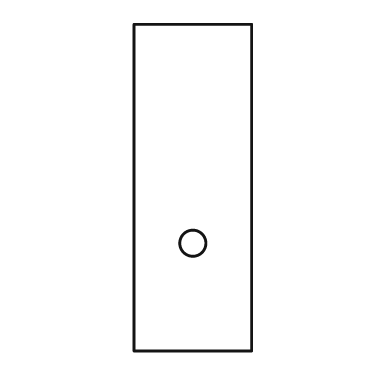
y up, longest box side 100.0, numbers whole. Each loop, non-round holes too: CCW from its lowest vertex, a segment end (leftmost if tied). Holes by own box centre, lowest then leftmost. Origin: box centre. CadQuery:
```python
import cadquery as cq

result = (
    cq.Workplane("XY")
    .moveTo(-18.0, -50.0)
    .lineTo(18.0, -50.0)
    .lineTo(18.0, 50.0)
    .lineTo(-18.0, 50.0)
    .close()
    .moveTo(0.0, -17.0)
    .circle(4.0)
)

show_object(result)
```